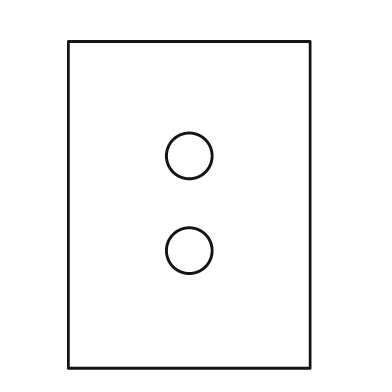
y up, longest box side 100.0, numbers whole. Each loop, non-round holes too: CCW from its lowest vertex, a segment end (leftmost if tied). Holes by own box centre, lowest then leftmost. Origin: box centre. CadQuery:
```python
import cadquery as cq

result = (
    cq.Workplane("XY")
    .moveTo(-37.0, -50.0)
    .lineTo(37.0, -50.0)
    .lineTo(37.0, 50.0)
    .lineTo(-37.0, 50.0)
    .close()
    .moveTo(0.0, -14.0)
    .circle(7.0)
    .moveTo(0.0, 15.0)
    .circle(7.0)
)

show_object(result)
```